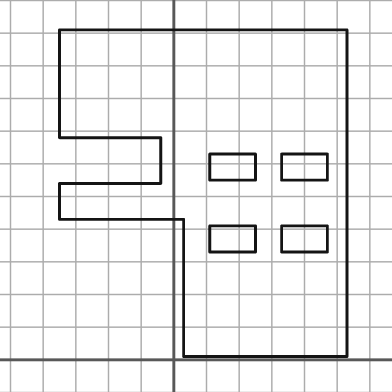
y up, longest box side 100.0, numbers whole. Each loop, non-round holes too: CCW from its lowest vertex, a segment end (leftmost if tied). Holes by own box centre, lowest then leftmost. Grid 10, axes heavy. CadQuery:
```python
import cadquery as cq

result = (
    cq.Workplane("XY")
    .moveTo(3.0, 1.0)
    .lineTo(53.0, 1.0)
    .lineTo(53.0, 101.0)
    .lineTo(-35.0, 101.0)
    .lineTo(-35.0, 68.0)
    .lineTo(-4.0, 68.0)
    .lineTo(-4.0, 54.0)
    .lineTo(-35.0, 54.0)
    .lineTo(-35.0, 43.0)
    .lineTo(3.0, 43.0)
    .close()
    .moveTo(11.0, 33.0)
    .lineTo(25.0, 33.0)
    .lineTo(25.0, 41.0)
    .lineTo(11.0, 41.0)
    .close()
    .moveTo(33.0, 33.0)
    .lineTo(47.0, 33.0)
    .lineTo(47.0, 41.0)
    .lineTo(33.0, 41.0)
    .close()
    .moveTo(11.0, 55.0)
    .lineTo(25.0, 55.0)
    .lineTo(25.0, 63.0)
    .lineTo(11.0, 63.0)
    .close()
    .moveTo(33.0, 55.0)
    .lineTo(47.0, 55.0)
    .lineTo(47.0, 63.0)
    .lineTo(33.0, 63.0)
    .close()
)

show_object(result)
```